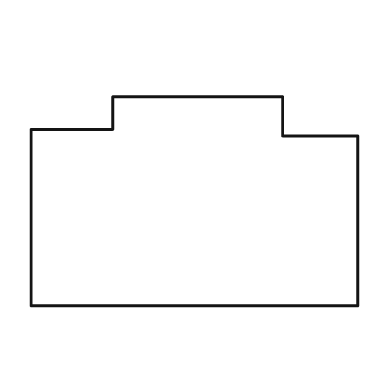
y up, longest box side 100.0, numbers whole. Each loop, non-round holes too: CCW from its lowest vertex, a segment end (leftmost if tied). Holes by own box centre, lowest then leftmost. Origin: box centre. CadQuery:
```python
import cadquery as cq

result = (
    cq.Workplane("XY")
    .moveTo(-50.0, -32.0)
    .lineTo(50.0, -32.0)
    .lineTo(50.0, 20.0)
    .lineTo(27.0, 20.0)
    .lineTo(27.0, 32.0)
    .lineTo(-25.0, 32.0)
    .lineTo(-25.0, 22.0)
    .lineTo(-50.0, 22.0)
    .close()
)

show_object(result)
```